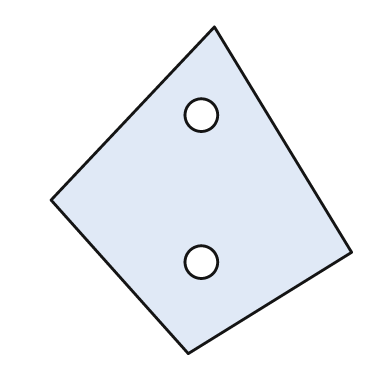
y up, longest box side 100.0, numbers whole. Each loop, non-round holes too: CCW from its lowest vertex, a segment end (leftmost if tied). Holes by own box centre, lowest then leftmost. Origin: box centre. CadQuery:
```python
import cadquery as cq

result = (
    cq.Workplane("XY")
    .moveTo(-4.0, -50.0)
    .lineTo(46.0, -19.0)
    .lineTo(4.0, 50.0)
    .lineTo(-46.0, -3.0)
    .close()
    .moveTo(0.0, -22.0)
    .circle(5.0)
    .moveTo(0.0, 23.0)
    .circle(5.0)
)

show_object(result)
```